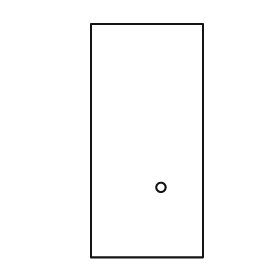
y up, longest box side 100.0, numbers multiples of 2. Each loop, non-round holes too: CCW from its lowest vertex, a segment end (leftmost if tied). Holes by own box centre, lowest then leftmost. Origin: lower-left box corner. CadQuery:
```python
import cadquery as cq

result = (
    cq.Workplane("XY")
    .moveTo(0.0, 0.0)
    .lineTo(48.0, 0.0)
    .lineTo(48.0, 100.0)
    .lineTo(0.0, 100.0)
    .close()
    .moveTo(30.0, 30.0)
    .circle(2.0)
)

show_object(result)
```